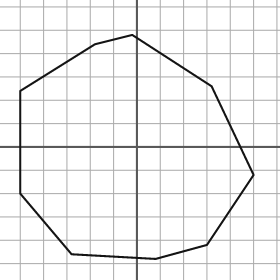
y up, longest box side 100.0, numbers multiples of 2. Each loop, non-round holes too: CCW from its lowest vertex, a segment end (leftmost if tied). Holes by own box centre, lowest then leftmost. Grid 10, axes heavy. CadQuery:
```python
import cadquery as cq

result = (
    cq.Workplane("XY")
    .moveTo(8.0, -48.0)
    .lineTo(30.0, -42.0)
    .lineTo(50.0, -12.0)
    .lineTo(32.0, 26.0)
    .lineTo(-2.0, 48.0)
    .lineTo(-18.0, 44.0)
    .lineTo(-50.0, 24.0)
    .lineTo(-50.0, -20.0)
    .lineTo(-28.0, -46.0)
    .close()
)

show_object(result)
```